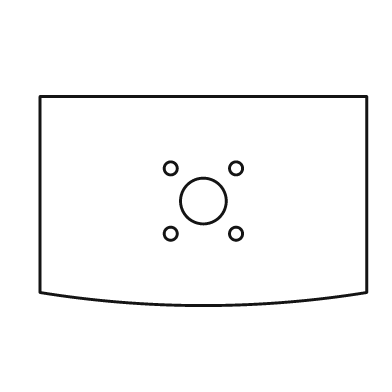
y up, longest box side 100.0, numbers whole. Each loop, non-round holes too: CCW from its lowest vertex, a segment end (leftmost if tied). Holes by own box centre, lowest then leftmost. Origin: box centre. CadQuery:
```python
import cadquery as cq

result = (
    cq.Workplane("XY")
    .moveTo(-50.0, -28.0)
    .threePointArc((0.0, -32.0), (50.0, -28.0))
    .lineTo(50.0, 32.0)
    .lineTo(-50.0, 32.0)
    .close()
    .moveTo(-10.0, -10.0)
    .circle(2.0)
    .moveTo(10.0, -10.0)
    .circle(2.0)
    .moveTo(0.0, 0.0)
    .circle(7.0)
    .moveTo(-10.0, 10.0)
    .circle(2.0)
    .moveTo(10.0, 10.0)
    .circle(2.0)
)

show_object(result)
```